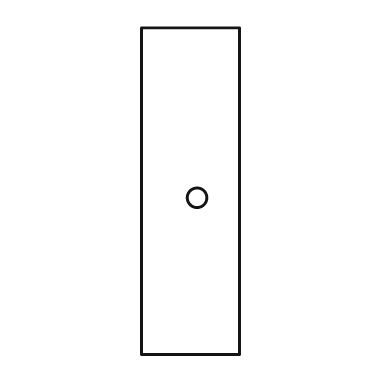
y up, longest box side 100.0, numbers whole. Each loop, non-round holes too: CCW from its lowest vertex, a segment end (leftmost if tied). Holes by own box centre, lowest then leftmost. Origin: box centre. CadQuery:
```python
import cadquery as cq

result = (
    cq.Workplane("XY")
    .moveTo(-15.0, -50.0)
    .lineTo(15.0, -50.0)
    .lineTo(15.0, 50.0)
    .lineTo(-15.0, 50.0)
    .close()
    .moveTo(2.0, -2.0)
    .circle(3.0)
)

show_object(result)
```